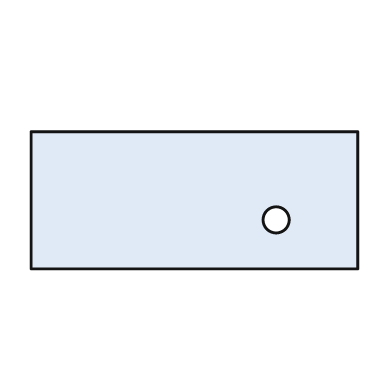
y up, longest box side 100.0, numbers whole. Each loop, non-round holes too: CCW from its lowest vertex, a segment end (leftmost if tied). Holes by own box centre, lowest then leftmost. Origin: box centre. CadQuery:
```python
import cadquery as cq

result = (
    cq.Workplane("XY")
    .moveTo(-50.0, -21.0)
    .lineTo(50.0, -21.0)
    .lineTo(50.0, 21.0)
    .lineTo(-50.0, 21.0)
    .close()
    .moveTo(25.0, -6.0)
    .circle(4.0)
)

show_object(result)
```